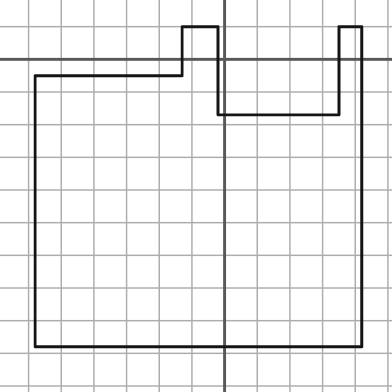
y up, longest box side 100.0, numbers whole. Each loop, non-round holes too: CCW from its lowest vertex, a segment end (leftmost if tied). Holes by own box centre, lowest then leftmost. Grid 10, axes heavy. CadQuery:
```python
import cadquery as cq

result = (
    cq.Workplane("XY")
    .moveTo(-58.0, -88.0)
    .lineTo(42.0, -88.0)
    .lineTo(42.0, 10.0)
    .lineTo(35.0, 10.0)
    .lineTo(35.0, -17.0)
    .lineTo(-2.0, -17.0)
    .lineTo(-2.0, 10.0)
    .lineTo(-13.0, 10.0)
    .lineTo(-13.0, -5.0)
    .lineTo(-58.0, -5.0)
    .close()
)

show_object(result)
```